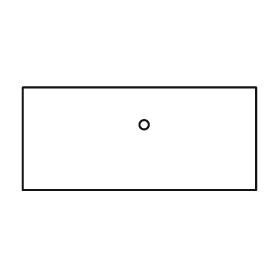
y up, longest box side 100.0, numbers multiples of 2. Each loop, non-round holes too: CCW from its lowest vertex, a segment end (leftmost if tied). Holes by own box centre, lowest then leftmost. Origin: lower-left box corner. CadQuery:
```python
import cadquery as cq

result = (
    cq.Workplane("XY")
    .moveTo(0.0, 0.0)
    .lineTo(100.0, 0.0)
    .lineTo(100.0, 44.0)
    .lineTo(0.0, 44.0)
    .close()
    .moveTo(52.0, 28.0)
    .circle(2.0)
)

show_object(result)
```